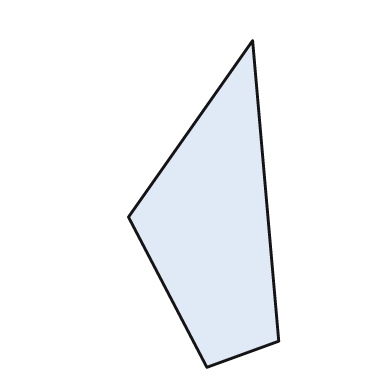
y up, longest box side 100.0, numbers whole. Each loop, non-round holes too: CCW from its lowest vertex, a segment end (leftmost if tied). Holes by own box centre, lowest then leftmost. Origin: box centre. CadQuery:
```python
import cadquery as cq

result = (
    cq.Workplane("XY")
    .moveTo(1.0, -50.0)
    .lineTo(23.0, -42.0)
    .lineTo(15.0, 50.0)
    .lineTo(-23.0, -4.0)
    .close()
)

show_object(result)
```